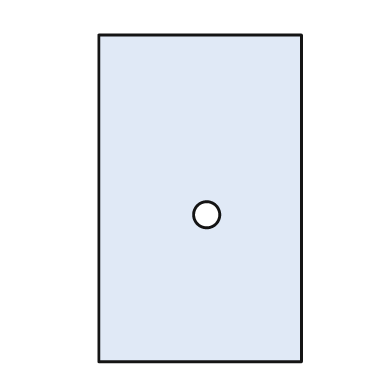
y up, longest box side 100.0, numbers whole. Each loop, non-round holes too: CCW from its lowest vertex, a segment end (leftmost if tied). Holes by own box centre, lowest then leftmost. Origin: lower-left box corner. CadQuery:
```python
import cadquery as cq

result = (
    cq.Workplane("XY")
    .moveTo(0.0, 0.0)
    .lineTo(62.0, 0.0)
    .lineTo(62.0, 100.0)
    .lineTo(0.0, 100.0)
    .close()
    .moveTo(33.0, 45.0)
    .circle(4.0)
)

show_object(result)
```